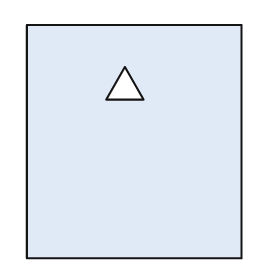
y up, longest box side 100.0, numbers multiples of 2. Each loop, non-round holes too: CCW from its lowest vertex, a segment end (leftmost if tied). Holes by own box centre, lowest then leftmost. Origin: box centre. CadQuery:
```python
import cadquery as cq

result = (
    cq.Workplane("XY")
    .moveTo(-46.0, -50.0)
    .lineTo(46.0, -50.0)
    .lineTo(46.0, 50.0)
    .lineTo(-46.0, 50.0)
    .close()
    .moveTo(-12.0, 18.0)
    .lineTo(4.0, 18.0)
    .lineTo(-4.0, 32.0)
    .close()
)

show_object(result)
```